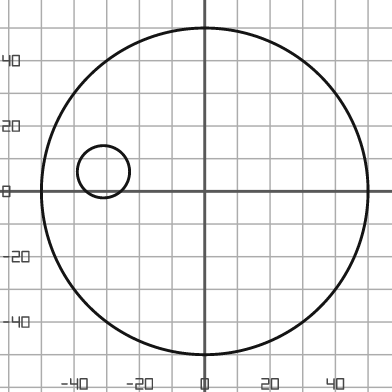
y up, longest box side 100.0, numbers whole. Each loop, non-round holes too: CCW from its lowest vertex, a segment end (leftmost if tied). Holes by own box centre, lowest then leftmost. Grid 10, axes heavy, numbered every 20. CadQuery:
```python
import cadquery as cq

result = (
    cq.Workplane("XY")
    .moveTo(0.0, 0.0)
    .circle(50.0)
    .moveTo(-31.0, 6.0)
    .circle(8.0)
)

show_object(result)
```